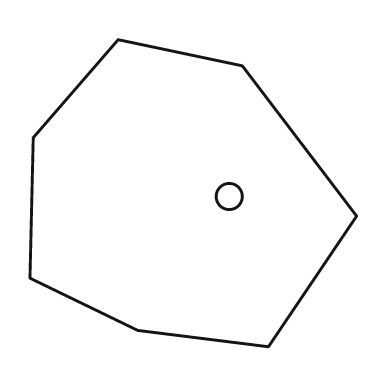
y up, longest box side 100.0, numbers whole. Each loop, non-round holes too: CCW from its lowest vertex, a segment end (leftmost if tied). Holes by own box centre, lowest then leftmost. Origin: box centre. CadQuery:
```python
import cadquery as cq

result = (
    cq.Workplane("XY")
    .moveTo(23.0, -47.0)
    .lineTo(50.0, -7.0)
    .lineTo(15.0, 39.0)
    .lineTo(-23.0, 47.0)
    .lineTo(-49.0, 17.0)
    .lineTo(-50.0, -26.0)
    .lineTo(-17.0, -42.0)
    .close()
    .moveTo(11.0, -1.0)
    .circle(4.0)
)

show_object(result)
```